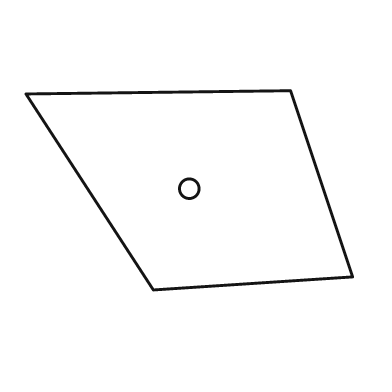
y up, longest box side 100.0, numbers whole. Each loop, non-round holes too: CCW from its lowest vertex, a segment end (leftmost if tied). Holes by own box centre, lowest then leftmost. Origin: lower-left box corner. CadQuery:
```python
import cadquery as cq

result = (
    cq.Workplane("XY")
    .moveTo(39.0, 0.0)
    .lineTo(100.0, 4.0)
    .lineTo(81.0, 61.0)
    .lineTo(0.0, 60.0)
    .close()
    .moveTo(50.0, 31.0)
    .circle(3.0)
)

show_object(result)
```